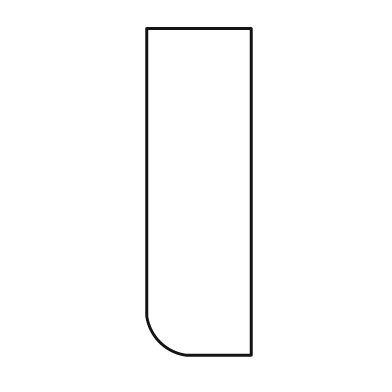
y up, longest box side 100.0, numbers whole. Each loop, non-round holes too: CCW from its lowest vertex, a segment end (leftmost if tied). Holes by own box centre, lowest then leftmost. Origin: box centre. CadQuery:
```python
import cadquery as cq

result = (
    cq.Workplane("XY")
    .moveTo(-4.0, -50.0)
    .lineTo(16.0, -50.0)
    .lineTo(16.0, 50.0)
    .lineTo(-16.0, 50.0)
    .lineTo(-16.0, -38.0)
    .threePointArc((-12.0, -46.0), (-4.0, -50.0))
    .close()
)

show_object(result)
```